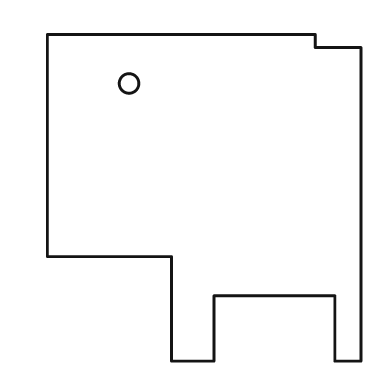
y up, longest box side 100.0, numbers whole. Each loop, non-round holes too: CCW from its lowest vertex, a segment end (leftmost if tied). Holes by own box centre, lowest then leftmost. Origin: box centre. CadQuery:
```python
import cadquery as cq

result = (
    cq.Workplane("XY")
    .moveTo(-10.0, -50.0)
    .lineTo(3.0, -50.0)
    .lineTo(3.0, -30.0)
    .lineTo(40.0, -30.0)
    .lineTo(40.0, -50.0)
    .lineTo(48.0, -50.0)
    .lineTo(48.0, 46.0)
    .lineTo(34.0, 46.0)
    .lineTo(34.0, 50.0)
    .lineTo(-48.0, 50.0)
    .lineTo(-48.0, -18.0)
    .lineTo(-10.0, -18.0)
    .close()
    .moveTo(-23.0, 35.0)
    .circle(3.0)
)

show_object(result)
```